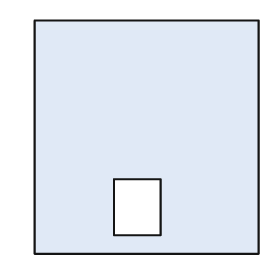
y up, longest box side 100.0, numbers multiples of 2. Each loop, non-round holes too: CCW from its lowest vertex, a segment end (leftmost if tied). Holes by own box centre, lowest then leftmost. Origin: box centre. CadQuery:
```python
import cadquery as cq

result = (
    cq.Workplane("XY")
    .moveTo(-48.0, -50.0)
    .lineTo(48.0, -50.0)
    .lineTo(48.0, 50.0)
    .lineTo(-48.0, 50.0)
    .close()
    .moveTo(-14.0, -42.0)
    .lineTo(6.0, -42.0)
    .lineTo(6.0, -18.0)
    .lineTo(-14.0, -18.0)
    .close()
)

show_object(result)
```